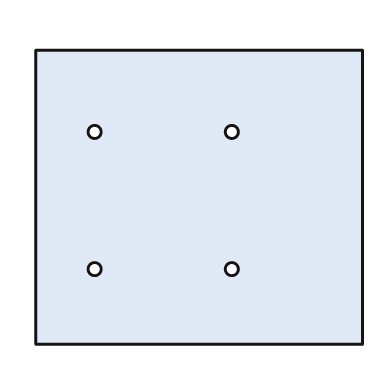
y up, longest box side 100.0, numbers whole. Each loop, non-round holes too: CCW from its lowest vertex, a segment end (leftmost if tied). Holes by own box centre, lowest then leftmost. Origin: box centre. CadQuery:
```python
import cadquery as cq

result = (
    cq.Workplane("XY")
    .moveTo(-50.0, -45.0)
    .lineTo(50.0, -45.0)
    .lineTo(50.0, 45.0)
    .lineTo(-50.0, 45.0)
    .close()
    .moveTo(-32.0, -22.0)
    .circle(2.0)
    .moveTo(10.0, -22.0)
    .circle(2.0)
    .moveTo(-32.0, 20.0)
    .circle(2.0)
    .moveTo(10.0, 20.0)
    .circle(2.0)
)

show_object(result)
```